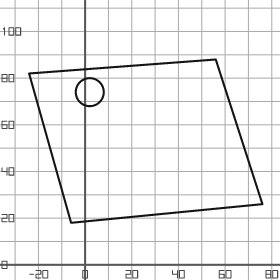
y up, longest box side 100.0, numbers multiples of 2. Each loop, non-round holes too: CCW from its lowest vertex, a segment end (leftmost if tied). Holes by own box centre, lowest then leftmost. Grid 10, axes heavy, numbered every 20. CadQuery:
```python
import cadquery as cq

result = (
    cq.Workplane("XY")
    .moveTo(-6.0, 18.0)
    .lineTo(76.0, 26.0)
    .lineTo(56.0, 88.0)
    .lineTo(-24.0, 82.0)
    .close()
    .moveTo(2.0, 74.0)
    .circle(6.0)
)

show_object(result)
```